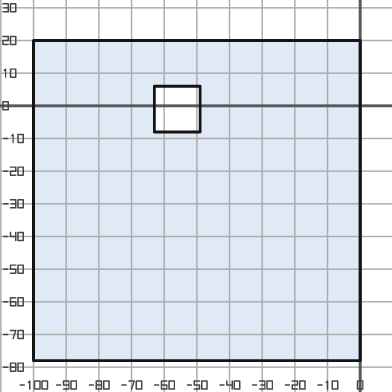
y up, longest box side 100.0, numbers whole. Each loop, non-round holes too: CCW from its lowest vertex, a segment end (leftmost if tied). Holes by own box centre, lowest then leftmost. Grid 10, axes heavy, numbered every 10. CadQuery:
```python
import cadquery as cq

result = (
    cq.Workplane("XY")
    .moveTo(-100.0, -78.0)
    .lineTo(0.0, -78.0)
    .lineTo(0.0, 20.0)
    .lineTo(-100.0, 20.0)
    .close()
    .moveTo(-63.0, -8.0)
    .lineTo(-49.0, -8.0)
    .lineTo(-49.0, 6.0)
    .lineTo(-63.0, 6.0)
    .close()
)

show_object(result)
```